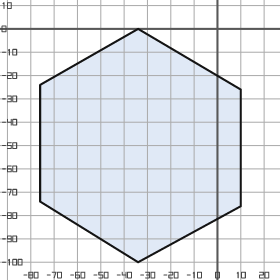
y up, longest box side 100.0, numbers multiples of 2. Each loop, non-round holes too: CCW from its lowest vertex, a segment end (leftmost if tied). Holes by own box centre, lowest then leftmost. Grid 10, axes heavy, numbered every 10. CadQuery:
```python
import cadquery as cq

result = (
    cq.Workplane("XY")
    .moveTo(-34.0, -100.0)
    .lineTo(10.0, -76.0)
    .lineTo(10.0, -26.0)
    .lineTo(-34.0, 0.0)
    .lineTo(-76.0, -24.0)
    .lineTo(-76.0, -74.0)
    .close()
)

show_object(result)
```